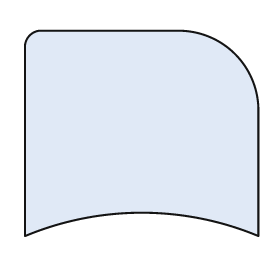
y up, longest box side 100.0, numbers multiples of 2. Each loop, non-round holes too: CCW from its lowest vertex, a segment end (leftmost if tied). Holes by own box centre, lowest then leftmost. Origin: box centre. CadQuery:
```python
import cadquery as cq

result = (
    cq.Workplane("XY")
    .moveTo(-50.0, -44.0)
    .threePointArc((0.0, -34.0), (50.0, -44.0))
    .lineTo(50.0, 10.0)
    .threePointArc((40.0, 34.0), (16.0, 44.0))
    .lineTo(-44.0, 44.0)
    .threePointArc((-48.0, 42.0), (-50.0, 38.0))
    .close()
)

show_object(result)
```